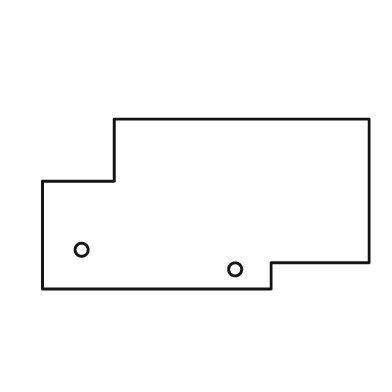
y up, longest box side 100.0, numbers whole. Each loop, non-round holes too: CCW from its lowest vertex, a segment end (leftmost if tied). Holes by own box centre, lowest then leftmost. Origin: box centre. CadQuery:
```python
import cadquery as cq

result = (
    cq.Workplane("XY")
    .moveTo(-50.0, -26.0)
    .lineTo(20.0, -26.0)
    .lineTo(20.0, -18.0)
    .lineTo(50.0, -18.0)
    .lineTo(50.0, 26.0)
    .lineTo(-28.0, 26.0)
    .lineTo(-28.0, 7.0)
    .lineTo(-50.0, 7.0)
    .close()
    .moveTo(9.0, -20.0)
    .circle(2.0)
    .moveTo(-38.0, -14.0)
    .circle(2.0)
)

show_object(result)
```